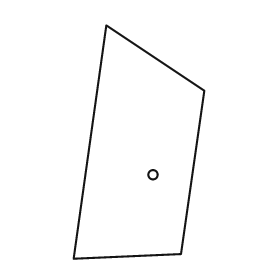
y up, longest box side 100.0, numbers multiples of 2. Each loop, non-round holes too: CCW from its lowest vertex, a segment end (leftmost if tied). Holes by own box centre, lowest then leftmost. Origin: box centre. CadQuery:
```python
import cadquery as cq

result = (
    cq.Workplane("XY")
    .moveTo(-28.0, -50.0)
    .lineTo(18.0, -48.0)
    .lineTo(28.0, 22.0)
    .lineTo(-14.0, 50.0)
    .close()
    .moveTo(6.0, -14.0)
    .circle(2.0)
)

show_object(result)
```